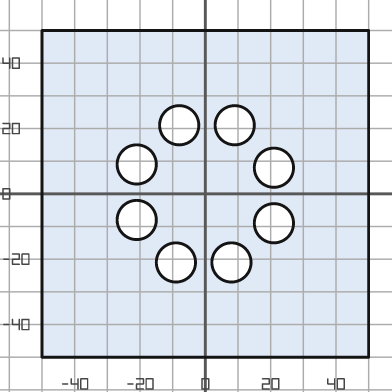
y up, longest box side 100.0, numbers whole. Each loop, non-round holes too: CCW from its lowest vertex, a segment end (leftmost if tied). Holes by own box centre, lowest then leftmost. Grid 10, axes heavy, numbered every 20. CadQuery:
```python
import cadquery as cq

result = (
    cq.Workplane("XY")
    .moveTo(-50.0, -50.0)
    .lineTo(50.0, -50.0)
    .lineTo(50.0, 50.0)
    .lineTo(-50.0, 50.0)
    .close()
    .moveTo(-9.0, -21.0)
    .circle(6.0)
    .moveTo(8.0, -21.0)
    .circle(6.0)
    .moveTo(21.0, -9.0)
    .circle(6.0)
    .moveTo(-21.0, -8.0)
    .circle(6.0)
    .moveTo(21.0, 8.0)
    .circle(6.0)
    .moveTo(-21.0, 9.0)
    .circle(6.0)
    .moveTo(-8.0, 21.0)
    .circle(6.0)
    .moveTo(9.0, 21.0)
    .circle(6.0)
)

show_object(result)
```